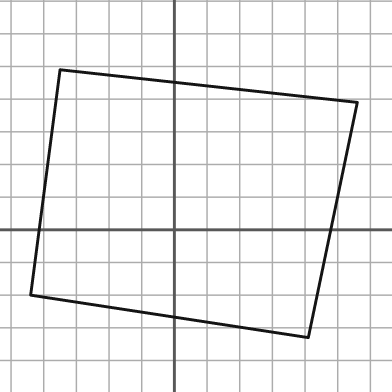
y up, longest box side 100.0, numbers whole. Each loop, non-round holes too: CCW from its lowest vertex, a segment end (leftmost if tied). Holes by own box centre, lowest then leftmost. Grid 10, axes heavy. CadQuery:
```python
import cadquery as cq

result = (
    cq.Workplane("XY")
    .moveTo(41.0, -33.0)
    .lineTo(56.0, 39.0)
    .lineTo(-35.0, 49.0)
    .lineTo(-44.0, -20.0)
    .close()
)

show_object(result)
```